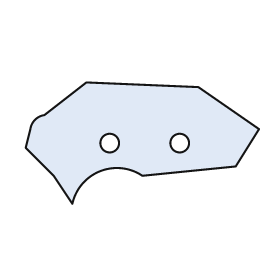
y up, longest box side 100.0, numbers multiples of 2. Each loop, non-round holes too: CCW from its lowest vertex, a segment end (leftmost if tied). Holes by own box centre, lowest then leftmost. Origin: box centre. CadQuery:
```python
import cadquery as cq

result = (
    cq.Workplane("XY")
    .moveTo(-30.0, -26.0)
    .threePointArc((-18.0, -12.0), (0.0, -14.0))
    .lineTo(40.0, -10.0)
    .lineTo(50.0, 6.0)
    .lineTo(24.0, 24.0)
    .lineTo(-24.0, 26.0)
    .lineTo(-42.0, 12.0)
    .threePointArc((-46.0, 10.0), (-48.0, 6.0))
    .lineTo(-50.0, -2.0)
    .lineTo(-38.0, -14.0)
    .close()
    .moveTo(-14.0, 0.0)
    .circle(4.0)
    .moveTo(16.0, 0.0)
    .circle(4.0)
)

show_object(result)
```